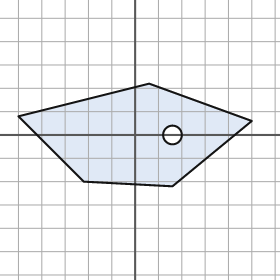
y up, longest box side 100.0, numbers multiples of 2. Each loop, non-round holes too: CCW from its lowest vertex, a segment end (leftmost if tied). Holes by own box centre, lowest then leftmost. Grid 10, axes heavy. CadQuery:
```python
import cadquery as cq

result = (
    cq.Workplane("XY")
    .moveTo(16.0, -22.0)
    .lineTo(50.0, 6.0)
    .lineTo(6.0, 22.0)
    .lineTo(-50.0, 8.0)
    .lineTo(-22.0, -20.0)
    .close()
    .moveTo(16.0, 0.0)
    .circle(4.0)
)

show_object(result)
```